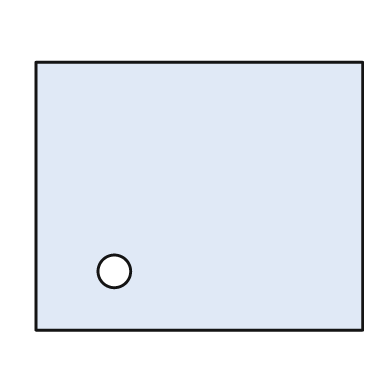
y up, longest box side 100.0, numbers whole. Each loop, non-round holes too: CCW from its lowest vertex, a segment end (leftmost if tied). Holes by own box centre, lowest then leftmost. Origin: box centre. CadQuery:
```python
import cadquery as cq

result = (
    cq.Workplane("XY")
    .moveTo(-50.0, -41.0)
    .lineTo(50.0, -41.0)
    .lineTo(50.0, 41.0)
    .lineTo(-50.0, 41.0)
    .close()
    .moveTo(-26.0, -23.0)
    .circle(5.0)
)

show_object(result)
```